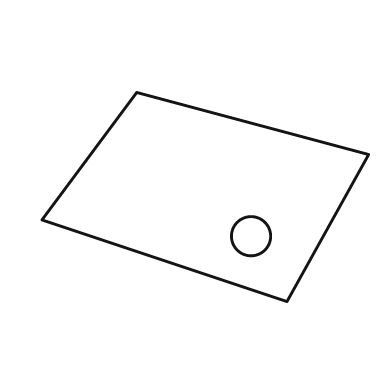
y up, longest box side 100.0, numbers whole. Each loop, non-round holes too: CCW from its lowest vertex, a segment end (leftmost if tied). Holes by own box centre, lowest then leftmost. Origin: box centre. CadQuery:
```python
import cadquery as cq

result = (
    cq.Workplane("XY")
    .moveTo(25.0, -32.0)
    .lineTo(50.0, 13.0)
    .lineTo(-21.0, 32.0)
    .lineTo(-50.0, -7.0)
    .close()
    .moveTo(14.0, -12.0)
    .circle(6.0)
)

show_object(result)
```